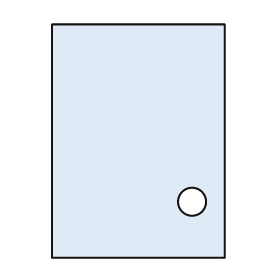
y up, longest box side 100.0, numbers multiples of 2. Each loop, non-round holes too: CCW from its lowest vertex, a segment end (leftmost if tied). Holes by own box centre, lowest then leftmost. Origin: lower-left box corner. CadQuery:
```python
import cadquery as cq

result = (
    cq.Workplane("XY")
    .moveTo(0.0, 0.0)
    .lineTo(74.0, 0.0)
    .lineTo(74.0, 100.0)
    .lineTo(0.0, 100.0)
    .close()
    .moveTo(60.0, 24.0)
    .circle(6.0)
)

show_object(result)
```